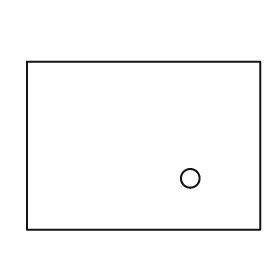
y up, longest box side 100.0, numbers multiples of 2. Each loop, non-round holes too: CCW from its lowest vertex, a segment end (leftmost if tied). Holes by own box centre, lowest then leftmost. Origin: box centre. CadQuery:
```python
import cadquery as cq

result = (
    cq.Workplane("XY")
    .moveTo(-50.0, -36.0)
    .lineTo(50.0, -36.0)
    .lineTo(50.0, 36.0)
    .lineTo(-50.0, 36.0)
    .close()
    .moveTo(20.0, -14.0)
    .circle(4.0)
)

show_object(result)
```